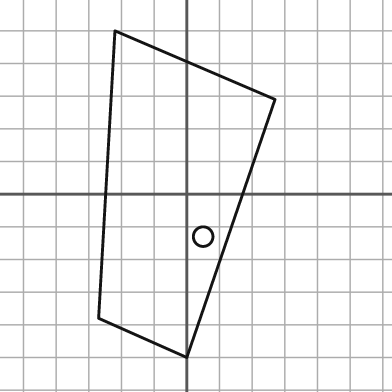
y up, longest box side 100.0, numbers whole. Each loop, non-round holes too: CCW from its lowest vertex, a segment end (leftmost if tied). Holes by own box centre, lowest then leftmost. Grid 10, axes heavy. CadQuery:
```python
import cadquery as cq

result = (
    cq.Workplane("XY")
    .moveTo(0.0, -50.0)
    .lineTo(27.0, 29.0)
    .lineTo(-22.0, 50.0)
    .lineTo(-27.0, -38.0)
    .close()
    .moveTo(5.0, -13.0)
    .circle(3.0)
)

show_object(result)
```